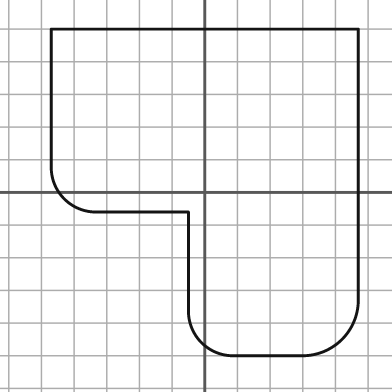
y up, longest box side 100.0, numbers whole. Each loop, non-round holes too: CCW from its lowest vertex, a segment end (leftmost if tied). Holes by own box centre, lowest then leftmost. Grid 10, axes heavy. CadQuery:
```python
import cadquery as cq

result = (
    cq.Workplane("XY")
    .moveTo(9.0, -50.0)
    .lineTo(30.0, -50.0)
    .threePointArc((42.0, -45.0), (47.0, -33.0))
    .lineTo(47.0, 50.0)
    .lineTo(-47.0, 50.0)
    .lineTo(-47.0, 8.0)
    .threePointArc((-43.0, -2.0), (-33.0, -6.0))
    .lineTo(-5.0, -6.0)
    .lineTo(-5.0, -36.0)
    .threePointArc((-1.0, -46.0), (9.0, -50.0))
    .close()
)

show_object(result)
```